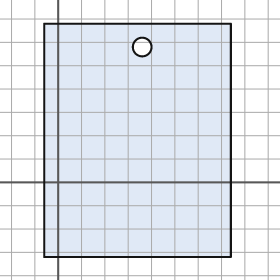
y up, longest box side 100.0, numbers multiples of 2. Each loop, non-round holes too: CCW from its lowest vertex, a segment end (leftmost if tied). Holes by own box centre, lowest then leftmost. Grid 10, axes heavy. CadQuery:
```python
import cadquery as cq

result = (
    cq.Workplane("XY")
    .moveTo(-6.0, -32.0)
    .lineTo(74.0, -32.0)
    .lineTo(74.0, 68.0)
    .lineTo(-6.0, 68.0)
    .close()
    .moveTo(36.0, 58.0)
    .circle(4.0)
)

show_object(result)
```